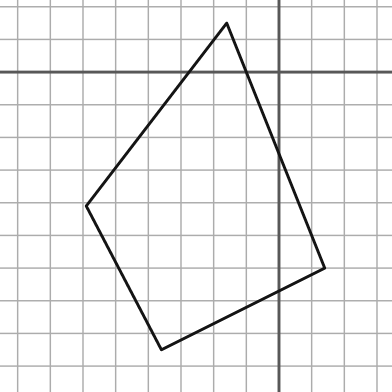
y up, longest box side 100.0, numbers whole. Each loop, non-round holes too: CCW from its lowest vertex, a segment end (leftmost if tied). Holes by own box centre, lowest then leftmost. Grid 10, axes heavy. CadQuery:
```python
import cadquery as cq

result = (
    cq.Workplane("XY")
    .moveTo(-36.0, -85.0)
    .lineTo(14.0, -60.0)
    .lineTo(-16.0, 15.0)
    .lineTo(-59.0, -41.0)
    .close()
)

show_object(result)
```